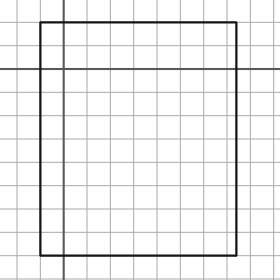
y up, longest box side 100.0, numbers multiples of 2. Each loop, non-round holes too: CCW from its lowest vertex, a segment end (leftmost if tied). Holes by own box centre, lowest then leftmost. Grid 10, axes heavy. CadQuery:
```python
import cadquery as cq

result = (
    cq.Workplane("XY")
    .moveTo(-10.0, -80.0)
    .lineTo(74.0, -80.0)
    .lineTo(74.0, 20.0)
    .lineTo(-10.0, 20.0)
    .close()
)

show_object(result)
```